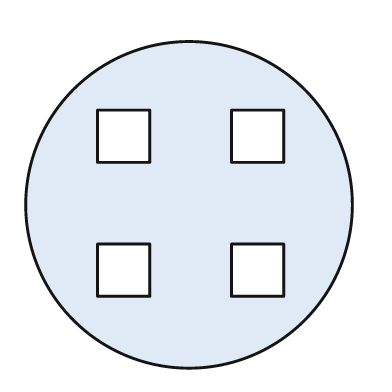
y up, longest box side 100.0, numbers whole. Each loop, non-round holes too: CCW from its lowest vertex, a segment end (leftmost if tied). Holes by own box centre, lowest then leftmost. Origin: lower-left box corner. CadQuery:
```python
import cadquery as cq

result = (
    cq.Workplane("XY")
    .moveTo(50.0, 50.0)
    .circle(50.0)
    .moveTo(22.0, 22.0)
    .lineTo(38.0, 22.0)
    .lineTo(38.0, 38.0)
    .lineTo(22.0, 38.0)
    .close()
    .moveTo(63.0, 22.0)
    .lineTo(79.0, 22.0)
    .lineTo(79.0, 38.0)
    .lineTo(63.0, 38.0)
    .close()
    .moveTo(22.0, 63.0)
    .lineTo(38.0, 63.0)
    .lineTo(38.0, 79.0)
    .lineTo(22.0, 79.0)
    .close()
    .moveTo(63.0, 63.0)
    .lineTo(79.0, 63.0)
    .lineTo(79.0, 79.0)
    .lineTo(63.0, 79.0)
    .close()
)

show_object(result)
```